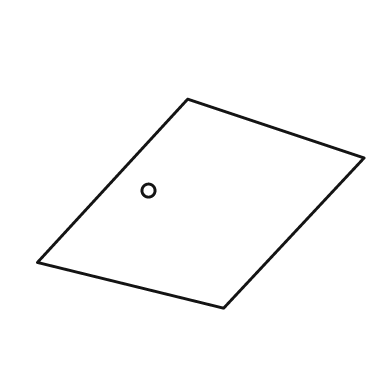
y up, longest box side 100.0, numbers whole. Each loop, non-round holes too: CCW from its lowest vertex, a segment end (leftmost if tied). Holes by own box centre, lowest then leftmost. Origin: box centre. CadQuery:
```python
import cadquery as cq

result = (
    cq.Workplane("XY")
    .moveTo(7.0, -32.0)
    .lineTo(50.0, 14.0)
    .lineTo(-4.0, 32.0)
    .lineTo(-50.0, -18.0)
    .close()
    .moveTo(-16.0, 4.0)
    .circle(2.0)
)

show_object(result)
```